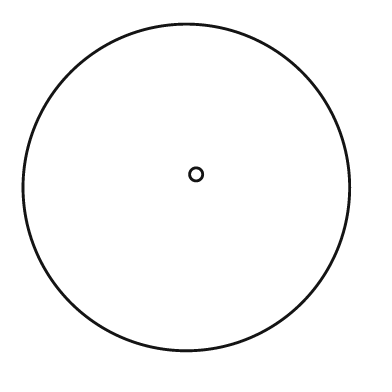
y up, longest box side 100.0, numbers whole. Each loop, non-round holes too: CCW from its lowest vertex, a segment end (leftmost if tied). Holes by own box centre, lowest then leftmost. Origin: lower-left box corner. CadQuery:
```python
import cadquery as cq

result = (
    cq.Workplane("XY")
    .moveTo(50.0, 50.0)
    .circle(50.0)
    .moveTo(53.0, 54.0)
    .circle(2.0)
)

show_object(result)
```